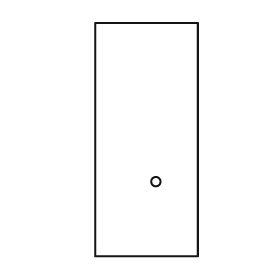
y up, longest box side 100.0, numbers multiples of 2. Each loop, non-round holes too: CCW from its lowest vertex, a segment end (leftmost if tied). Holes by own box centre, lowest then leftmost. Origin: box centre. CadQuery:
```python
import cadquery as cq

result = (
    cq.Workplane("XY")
    .moveTo(-22.0, -50.0)
    .lineTo(22.0, -50.0)
    .lineTo(22.0, 50.0)
    .lineTo(-22.0, 50.0)
    .close()
    .moveTo(4.0, -18.0)
    .circle(2.0)
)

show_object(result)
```